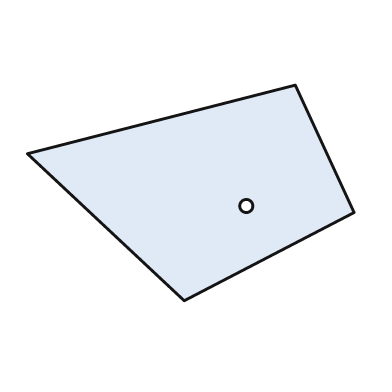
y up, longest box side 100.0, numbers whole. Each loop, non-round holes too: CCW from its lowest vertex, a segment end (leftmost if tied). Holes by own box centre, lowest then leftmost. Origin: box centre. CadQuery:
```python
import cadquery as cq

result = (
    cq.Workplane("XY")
    .moveTo(-2.0, -33.0)
    .lineTo(50.0, -6.0)
    .lineTo(32.0, 33.0)
    .lineTo(-50.0, 12.0)
    .close()
    .moveTo(17.0, -4.0)
    .circle(2.0)
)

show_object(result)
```